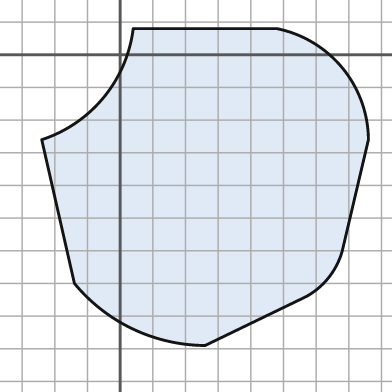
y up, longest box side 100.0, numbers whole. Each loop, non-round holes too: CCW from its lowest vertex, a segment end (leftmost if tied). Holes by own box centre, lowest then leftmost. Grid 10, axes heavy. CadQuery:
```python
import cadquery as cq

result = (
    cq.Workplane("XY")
    .moveTo(26.0, -89.0)
    .lineTo(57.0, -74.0)
    .threePointArc((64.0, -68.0), (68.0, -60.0))
    .lineTo(76.0, -26.0)
    .threePointArc((68.0, -4.0), (48.0, 8.0))
    .lineTo(4.0, 8.0)
    .threePointArc((-5.0, -13.0), (-24.0, -26.0))
    .lineTo(-14.0, -70.0)
    .threePointArc((4.0, -84.0), (26.0, -89.0))
    .close()
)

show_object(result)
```